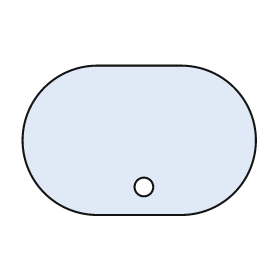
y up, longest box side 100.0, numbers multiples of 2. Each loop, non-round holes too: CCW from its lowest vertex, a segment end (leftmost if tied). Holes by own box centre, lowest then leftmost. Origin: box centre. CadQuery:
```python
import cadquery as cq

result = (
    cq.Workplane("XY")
    .moveTo(-18.0, -32.0)
    .lineTo(18.0, -32.0)
    .threePointArc((50.0, 0.0), (18.0, 32.0))
    .lineTo(-18.0, 32.0)
    .threePointArc((-50.0, 0.0), (-18.0, -32.0))
    .close()
    .moveTo(2.0, -20.0)
    .circle(4.0)
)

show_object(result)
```